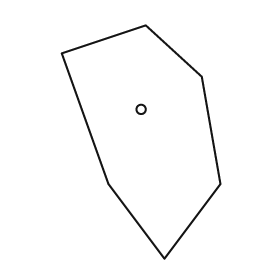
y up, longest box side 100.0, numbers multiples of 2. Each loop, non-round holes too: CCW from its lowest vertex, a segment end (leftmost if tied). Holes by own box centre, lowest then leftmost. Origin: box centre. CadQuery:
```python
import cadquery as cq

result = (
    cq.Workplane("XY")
    .moveTo(10.0, -50.0)
    .lineTo(34.0, -18.0)
    .lineTo(26.0, 28.0)
    .lineTo(2.0, 50.0)
    .lineTo(-34.0, 38.0)
    .lineTo(-14.0, -18.0)
    .close()
    .moveTo(0.0, 14.0)
    .circle(2.0)
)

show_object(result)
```